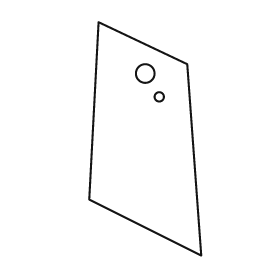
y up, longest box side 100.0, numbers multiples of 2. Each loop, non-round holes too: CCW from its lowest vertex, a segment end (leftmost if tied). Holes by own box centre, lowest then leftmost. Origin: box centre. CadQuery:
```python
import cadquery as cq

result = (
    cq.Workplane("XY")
    .moveTo(24.0, -50.0)
    .lineTo(18.0, 32.0)
    .lineTo(-20.0, 50.0)
    .lineTo(-24.0, -26.0)
    .close()
    .moveTo(6.0, 18.0)
    .circle(2.0)
    .moveTo(0.0, 28.0)
    .circle(4.0)
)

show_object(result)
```